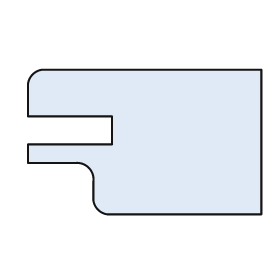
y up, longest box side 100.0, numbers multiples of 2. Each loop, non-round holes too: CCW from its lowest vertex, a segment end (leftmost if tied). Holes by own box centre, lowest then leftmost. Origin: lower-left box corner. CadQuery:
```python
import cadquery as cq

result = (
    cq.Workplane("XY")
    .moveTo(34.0, 0.0)
    .lineTo(100.0, 0.0)
    .lineTo(100.0, 62.0)
    .lineTo(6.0, 62.0)
    .threePointArc((2.0, 60.0), (0.0, 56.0))
    .lineTo(0.0, 42.0)
    .lineTo(36.0, 42.0)
    .lineTo(36.0, 30.0)
    .lineTo(0.0, 30.0)
    .lineTo(0.0, 22.0)
    .lineTo(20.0, 22.0)
    .threePointArc((26.0, 20.0), (28.0, 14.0))
    .lineTo(28.0, 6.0)
    .threePointArc((30.0, 2.0), (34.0, 0.0))
    .close()
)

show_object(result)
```